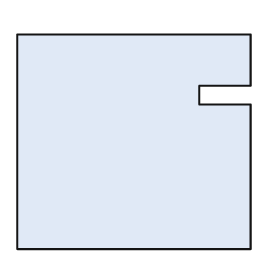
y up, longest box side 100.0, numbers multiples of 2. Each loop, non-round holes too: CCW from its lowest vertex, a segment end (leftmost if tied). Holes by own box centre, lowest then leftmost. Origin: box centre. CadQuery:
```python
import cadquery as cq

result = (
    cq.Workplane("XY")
    .moveTo(-50.0, -46.0)
    .lineTo(50.0, -46.0)
    .lineTo(50.0, 16.0)
    .lineTo(28.0, 16.0)
    .lineTo(28.0, 24.0)
    .lineTo(50.0, 24.0)
    .lineTo(50.0, 46.0)
    .lineTo(-50.0, 46.0)
    .close()
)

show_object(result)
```